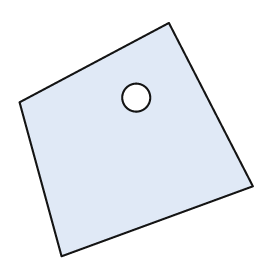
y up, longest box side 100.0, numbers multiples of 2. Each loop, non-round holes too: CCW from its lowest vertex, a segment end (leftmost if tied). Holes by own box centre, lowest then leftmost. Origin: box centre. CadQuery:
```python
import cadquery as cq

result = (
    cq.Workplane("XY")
    .moveTo(-32.0, -50.0)
    .lineTo(50.0, -20.0)
    .lineTo(14.0, 50.0)
    .lineTo(-50.0, 16.0)
    .close()
    .moveTo(0.0, 18.0)
    .circle(6.0)
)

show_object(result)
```